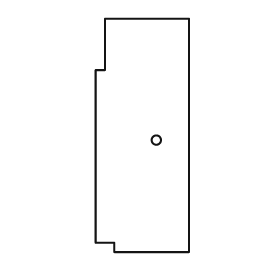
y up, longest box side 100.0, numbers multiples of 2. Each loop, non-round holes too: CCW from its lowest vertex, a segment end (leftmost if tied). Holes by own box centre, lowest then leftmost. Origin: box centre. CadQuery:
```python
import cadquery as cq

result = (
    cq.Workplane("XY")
    .moveTo(-12.0, -50.0)
    .lineTo(20.0, -50.0)
    .lineTo(20.0, 50.0)
    .lineTo(-16.0, 50.0)
    .lineTo(-16.0, 28.0)
    .lineTo(-20.0, 28.0)
    .lineTo(-20.0, -46.0)
    .lineTo(-12.0, -46.0)
    .close()
    .moveTo(6.0, -2.0)
    .circle(2.0)
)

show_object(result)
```